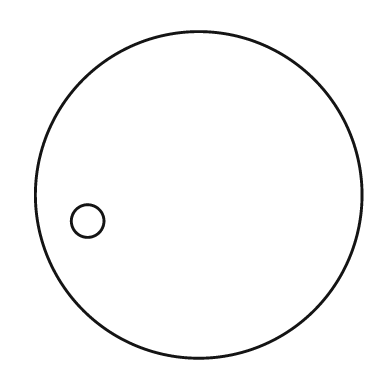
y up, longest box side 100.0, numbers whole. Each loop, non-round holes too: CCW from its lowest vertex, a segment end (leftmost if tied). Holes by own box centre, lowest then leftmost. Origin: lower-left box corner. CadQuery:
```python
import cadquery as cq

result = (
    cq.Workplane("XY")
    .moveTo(50.0, 50.0)
    .circle(50.0)
    .moveTo(16.0, 42.0)
    .circle(5.0)
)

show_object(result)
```